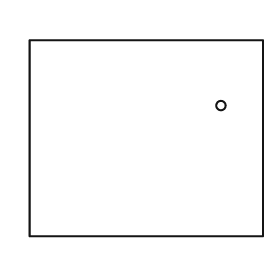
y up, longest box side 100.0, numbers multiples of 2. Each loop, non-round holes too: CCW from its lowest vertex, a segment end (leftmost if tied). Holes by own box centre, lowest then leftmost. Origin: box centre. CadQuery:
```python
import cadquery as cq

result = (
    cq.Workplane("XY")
    .moveTo(-50.0, -42.0)
    .lineTo(50.0, -42.0)
    .lineTo(50.0, 42.0)
    .lineTo(-50.0, 42.0)
    .close()
    .moveTo(32.0, 14.0)
    .circle(2.0)
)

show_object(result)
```